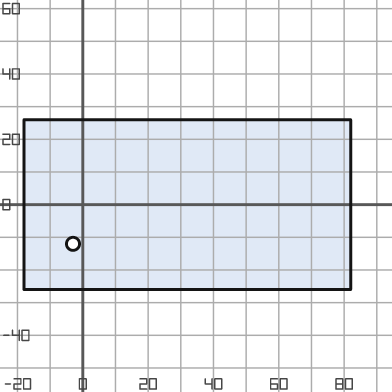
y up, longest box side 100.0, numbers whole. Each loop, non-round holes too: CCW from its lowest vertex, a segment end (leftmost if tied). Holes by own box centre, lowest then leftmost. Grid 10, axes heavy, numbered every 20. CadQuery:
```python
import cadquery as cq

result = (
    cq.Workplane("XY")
    .moveTo(-18.0, -26.0)
    .lineTo(82.0, -26.0)
    .lineTo(82.0, 26.0)
    .lineTo(-18.0, 26.0)
    .close()
    .moveTo(-3.0, -12.0)
    .circle(2.0)
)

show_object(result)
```